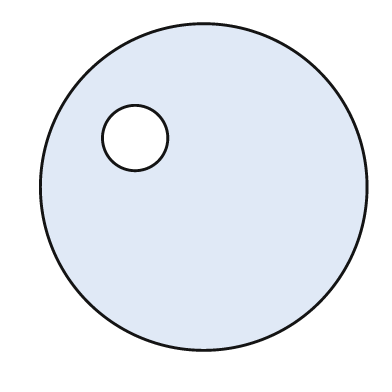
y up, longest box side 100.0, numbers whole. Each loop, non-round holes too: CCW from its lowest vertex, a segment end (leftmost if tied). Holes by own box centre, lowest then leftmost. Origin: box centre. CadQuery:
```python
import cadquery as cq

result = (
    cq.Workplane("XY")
    .moveTo(0.0, 0.0)
    .circle(50.0)
    .moveTo(-21.0, 15.0)
    .circle(10.0)
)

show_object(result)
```